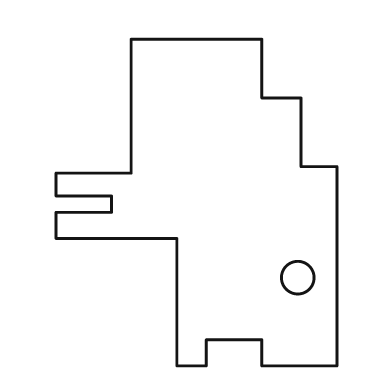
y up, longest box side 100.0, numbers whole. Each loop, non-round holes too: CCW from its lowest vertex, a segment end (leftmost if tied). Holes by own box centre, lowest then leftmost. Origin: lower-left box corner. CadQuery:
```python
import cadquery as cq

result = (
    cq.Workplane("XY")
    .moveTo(37.0, 0.0)
    .lineTo(46.0, 0.0)
    .lineTo(46.0, 8.0)
    .lineTo(63.0, 8.0)
    .lineTo(63.0, 0.0)
    .lineTo(86.0, 0.0)
    .lineTo(86.0, 61.0)
    .lineTo(75.0, 61.0)
    .lineTo(75.0, 82.0)
    .lineTo(63.0, 82.0)
    .lineTo(63.0, 100.0)
    .lineTo(23.0, 100.0)
    .lineTo(23.0, 59.0)
    .lineTo(0.0, 59.0)
    .lineTo(0.0, 52.0)
    .lineTo(17.0, 52.0)
    .lineTo(17.0, 47.0)
    .lineTo(0.0, 47.0)
    .lineTo(0.0, 39.0)
    .lineTo(37.0, 39.0)
    .close()
    .moveTo(74.0, 27.0)
    .circle(5.0)
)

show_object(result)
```